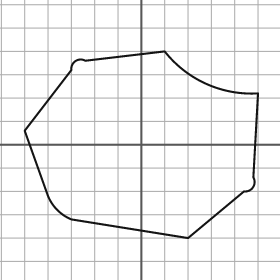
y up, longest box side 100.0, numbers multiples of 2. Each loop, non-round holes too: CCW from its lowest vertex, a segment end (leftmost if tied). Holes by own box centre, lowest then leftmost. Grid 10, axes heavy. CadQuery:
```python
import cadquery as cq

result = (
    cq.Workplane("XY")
    .moveTo(20.0, -40.0)
    .lineTo(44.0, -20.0)
    .threePointArc((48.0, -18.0), (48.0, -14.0))
    .lineTo(50.0, 22.0)
    .threePointArc((28.0, 26.0), (10.0, 40.0))
    .lineTo(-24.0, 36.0)
    .threePointArc((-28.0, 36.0), (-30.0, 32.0))
    .lineTo(-50.0, 6.0)
    .lineTo(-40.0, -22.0)
    .threePointArc((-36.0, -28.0), (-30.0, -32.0))
    .close()
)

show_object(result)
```